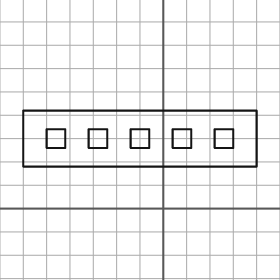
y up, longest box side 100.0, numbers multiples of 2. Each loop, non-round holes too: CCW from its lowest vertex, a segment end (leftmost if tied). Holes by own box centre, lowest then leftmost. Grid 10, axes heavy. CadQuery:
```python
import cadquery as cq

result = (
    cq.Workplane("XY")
    .moveTo(-60.0, 18.0)
    .lineTo(40.0, 18.0)
    .lineTo(40.0, 42.0)
    .lineTo(-60.0, 42.0)
    .close()
    .moveTo(-50.0, 26.0)
    .lineTo(-42.0, 26.0)
    .lineTo(-42.0, 34.0)
    .lineTo(-50.0, 34.0)
    .close()
    .moveTo(-32.0, 26.0)
    .lineTo(-24.0, 26.0)
    .lineTo(-24.0, 34.0)
    .lineTo(-32.0, 34.0)
    .close()
    .moveTo(-14.0, 26.0)
    .lineTo(-6.0, 26.0)
    .lineTo(-6.0, 34.0)
    .lineTo(-14.0, 34.0)
    .close()
    .moveTo(4.0, 26.0)
    .lineTo(12.0, 26.0)
    .lineTo(12.0, 34.0)
    .lineTo(4.0, 34.0)
    .close()
    .moveTo(22.0, 26.0)
    .lineTo(30.0, 26.0)
    .lineTo(30.0, 34.0)
    .lineTo(22.0, 34.0)
    .close()
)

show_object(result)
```